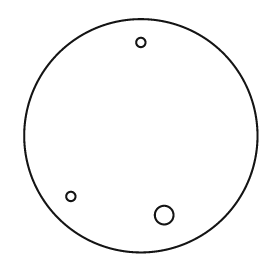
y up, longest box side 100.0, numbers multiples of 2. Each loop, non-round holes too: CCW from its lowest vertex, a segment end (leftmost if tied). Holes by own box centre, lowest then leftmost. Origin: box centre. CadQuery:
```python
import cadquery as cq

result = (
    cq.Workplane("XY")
    .moveTo(0.0, 0.0)
    .circle(50.0)
    .moveTo(10.0, -34.0)
    .circle(4.0)
    .moveTo(-30.0, -26.0)
    .circle(2.0)
    .moveTo(0.0, 40.0)
    .circle(2.0)
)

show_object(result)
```